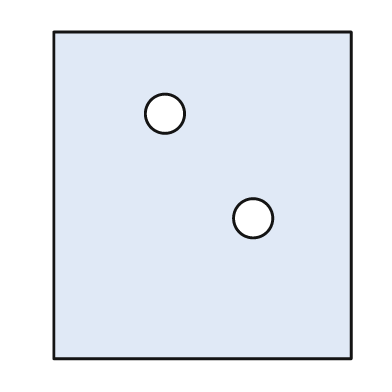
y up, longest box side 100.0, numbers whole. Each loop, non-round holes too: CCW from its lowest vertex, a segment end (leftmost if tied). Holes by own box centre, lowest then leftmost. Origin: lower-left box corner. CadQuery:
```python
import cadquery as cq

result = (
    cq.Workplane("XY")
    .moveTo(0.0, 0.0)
    .lineTo(91.0, 0.0)
    .lineTo(91.0, 100.0)
    .lineTo(0.0, 100.0)
    .close()
    .moveTo(61.0, 43.0)
    .circle(6.0)
    .moveTo(34.0, 75.0)
    .circle(6.0)
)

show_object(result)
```